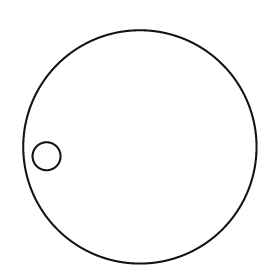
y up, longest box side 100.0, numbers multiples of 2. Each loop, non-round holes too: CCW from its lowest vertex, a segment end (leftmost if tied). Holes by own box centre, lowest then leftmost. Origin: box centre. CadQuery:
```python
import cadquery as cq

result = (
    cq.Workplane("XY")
    .moveTo(0.0, 0.0)
    .circle(50.0)
    .moveTo(-40.0, -4.0)
    .circle(6.0)
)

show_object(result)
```